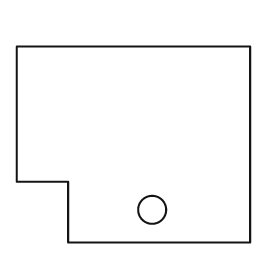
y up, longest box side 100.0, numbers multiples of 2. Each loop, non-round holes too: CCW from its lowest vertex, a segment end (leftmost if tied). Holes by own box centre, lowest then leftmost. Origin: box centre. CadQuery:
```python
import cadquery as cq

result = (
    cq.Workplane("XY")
    .moveTo(-28.0, -42.0)
    .lineTo(50.0, -42.0)
    .lineTo(50.0, 42.0)
    .lineTo(-50.0, 42.0)
    .lineTo(-50.0, -16.0)
    .lineTo(-28.0, -16.0)
    .close()
    .moveTo(8.0, -28.0)
    .circle(6.0)
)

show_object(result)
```